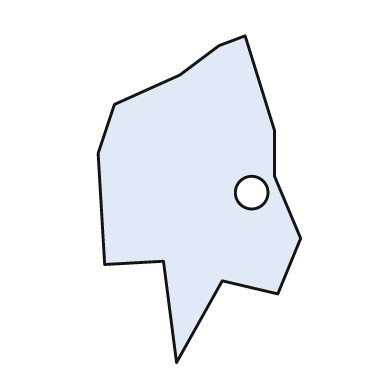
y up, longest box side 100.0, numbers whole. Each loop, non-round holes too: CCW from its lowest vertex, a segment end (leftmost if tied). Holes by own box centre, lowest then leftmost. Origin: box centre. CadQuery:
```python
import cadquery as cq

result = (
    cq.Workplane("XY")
    .moveTo(-7.0, -50.0)
    .lineTo(7.0, -25.0)
    .lineTo(24.0, -29.0)
    .lineTo(31.0, -12.0)
    .lineTo(23.0, 7.0)
    .lineTo(23.0, 21.0)
    .lineTo(14.0, 50.0)
    .lineTo(6.0, 47.0)
    .lineTo(-6.0, 38.0)
    .lineTo(-26.0, 29.0)
    .lineTo(-31.0, 14.0)
    .lineTo(-29.0, -20.0)
    .lineTo(-11.0, -19.0)
    .close()
    .moveTo(16.0, 2.0)
    .circle(5.0)
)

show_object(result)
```